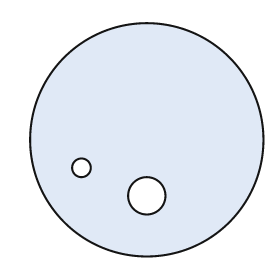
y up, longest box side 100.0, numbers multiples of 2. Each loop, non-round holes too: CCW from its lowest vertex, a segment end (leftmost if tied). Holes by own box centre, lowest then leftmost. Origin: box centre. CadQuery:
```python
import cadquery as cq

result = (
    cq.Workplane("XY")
    .moveTo(0.0, 0.0)
    .circle(50.0)
    .moveTo(0.0, -24.0)
    .circle(8.0)
    .moveTo(-28.0, -12.0)
    .circle(4.0)
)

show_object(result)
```